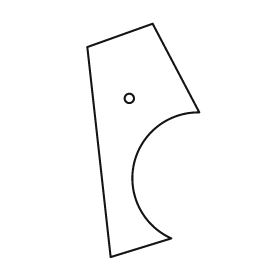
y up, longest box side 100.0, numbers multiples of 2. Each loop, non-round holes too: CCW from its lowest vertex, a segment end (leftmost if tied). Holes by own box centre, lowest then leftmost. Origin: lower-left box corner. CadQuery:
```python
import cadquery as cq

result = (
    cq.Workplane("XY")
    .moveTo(10.0, 0.0)
    .lineTo(36.0, 8.0)
    .threePointArc((20.0, 40.0), (48.0, 62.0))
    .lineTo(28.0, 100.0)
    .lineTo(0.0, 90.0)
    .close()
    .moveTo(18.0, 68.0)
    .circle(2.0)
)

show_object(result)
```